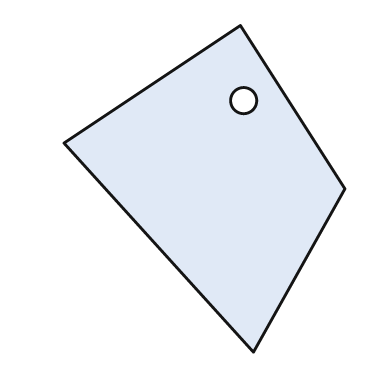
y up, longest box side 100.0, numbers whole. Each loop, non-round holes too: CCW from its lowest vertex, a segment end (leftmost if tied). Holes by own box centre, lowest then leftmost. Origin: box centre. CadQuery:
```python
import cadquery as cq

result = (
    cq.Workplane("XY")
    .moveTo(15.0, -50.0)
    .lineTo(43.0, 0.0)
    .lineTo(11.0, 50.0)
    .lineTo(-43.0, 14.0)
    .close()
    .moveTo(12.0, 27.0)
    .circle(4.0)
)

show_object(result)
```